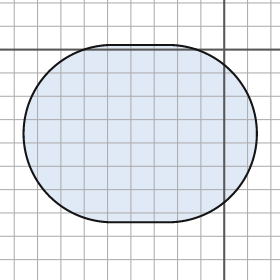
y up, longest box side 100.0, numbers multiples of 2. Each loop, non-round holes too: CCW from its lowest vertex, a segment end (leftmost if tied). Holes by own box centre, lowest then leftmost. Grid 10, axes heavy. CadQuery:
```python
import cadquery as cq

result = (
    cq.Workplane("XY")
    .moveTo(-48.0, -74.0)
    .lineTo(-24.0, -74.0)
    .threePointArc((14.0, -36.0), (-24.0, 2.0))
    .lineTo(-48.0, 2.0)
    .threePointArc((-86.0, -36.0), (-48.0, -74.0))
    .close()
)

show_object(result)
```